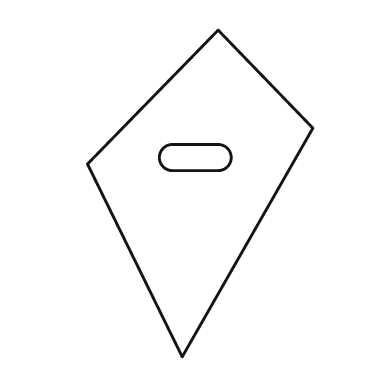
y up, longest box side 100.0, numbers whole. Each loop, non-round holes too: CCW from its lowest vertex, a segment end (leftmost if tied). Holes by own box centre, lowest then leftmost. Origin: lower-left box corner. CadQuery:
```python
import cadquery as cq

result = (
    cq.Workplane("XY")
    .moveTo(29.0, 0.0)
    .lineTo(69.0, 70.0)
    .lineTo(40.0, 100.0)
    .lineTo(0.0, 59.0)
    .close()
    .moveTo(26.0, 57.0)
    .lineTo(40.0, 57.0)
    .threePointArc((44.0, 61.0), (40.0, 65.0))
    .lineTo(26.0, 65.0)
    .threePointArc((22.0, 61.0), (26.0, 57.0))
    .close()
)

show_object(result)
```